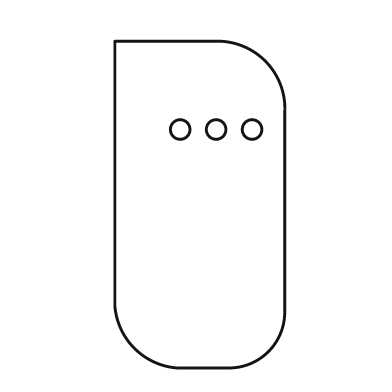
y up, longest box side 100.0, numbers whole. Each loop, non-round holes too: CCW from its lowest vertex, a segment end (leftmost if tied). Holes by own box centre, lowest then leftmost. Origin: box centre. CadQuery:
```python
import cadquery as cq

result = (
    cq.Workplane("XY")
    .moveTo(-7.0, -50.0)
    .lineTo(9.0, -50.0)
    .threePointArc((21.0, -45.0), (26.0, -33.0))
    .lineTo(26.0, 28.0)
    .threePointArc((20.0, 44.0), (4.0, 50.0))
    .lineTo(-26.0, 50.0)
    .lineTo(-26.0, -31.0)
    .threePointArc((-20.0, -44.0), (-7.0, -50.0))
    .close()
    .moveTo(-6.0, 23.0)
    .circle(3.0)
    .moveTo(5.0, 23.0)
    .circle(3.0)
    .moveTo(16.0, 23.0)
    .circle(3.0)
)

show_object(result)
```